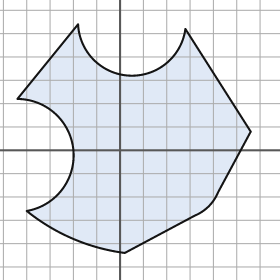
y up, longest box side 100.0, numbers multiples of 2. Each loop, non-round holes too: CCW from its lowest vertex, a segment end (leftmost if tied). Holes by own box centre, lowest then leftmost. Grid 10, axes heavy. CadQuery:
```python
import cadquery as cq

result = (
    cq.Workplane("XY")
    .moveTo(2.0, -44.0)
    .lineTo(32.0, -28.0)
    .threePointArc((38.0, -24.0), (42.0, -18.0))
    .lineTo(56.0, 8.0)
    .lineTo(28.0, 52.0)
    .threePointArc((4.0, 32.0), (-18.0, 54.0))
    .lineTo(-44.0, 22.0)
    .threePointArc((-20.0, 0.0), (-40.0, -26.0))
    .threePointArc((-20.0, -38.0), (2.0, -44.0))
    .close()
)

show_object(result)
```